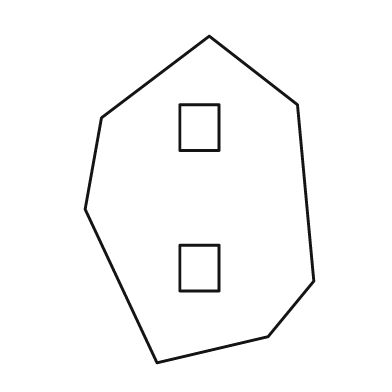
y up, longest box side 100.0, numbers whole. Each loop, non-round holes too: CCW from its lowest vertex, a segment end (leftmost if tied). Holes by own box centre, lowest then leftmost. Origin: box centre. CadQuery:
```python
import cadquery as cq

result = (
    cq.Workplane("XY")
    .moveTo(-13.0, -50.0)
    .lineTo(21.0, -42.0)
    .lineTo(35.0, -25.0)
    .lineTo(30.0, 29.0)
    .lineTo(3.0, 50.0)
    .lineTo(-30.0, 25.0)
    .lineTo(-35.0, -3.0)
    .close()
    .moveTo(-6.0, -28.0)
    .lineTo(6.0, -28.0)
    .lineTo(6.0, -14.0)
    .lineTo(-6.0, -14.0)
    .close()
    .moveTo(-6.0, 15.0)
    .lineTo(6.0, 15.0)
    .lineTo(6.0, 29.0)
    .lineTo(-6.0, 29.0)
    .close()
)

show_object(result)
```